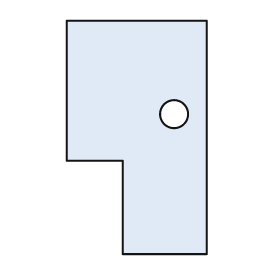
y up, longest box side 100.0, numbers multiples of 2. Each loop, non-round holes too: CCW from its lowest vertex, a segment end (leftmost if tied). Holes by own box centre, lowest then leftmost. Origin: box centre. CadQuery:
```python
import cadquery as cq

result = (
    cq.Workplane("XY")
    .moveTo(-6.0, -50.0)
    .lineTo(30.0, -50.0)
    .lineTo(30.0, 50.0)
    .lineTo(-30.0, 50.0)
    .lineTo(-30.0, -10.0)
    .lineTo(-6.0, -10.0)
    .close()
    .moveTo(16.0, 10.0)
    .circle(6.0)
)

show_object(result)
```